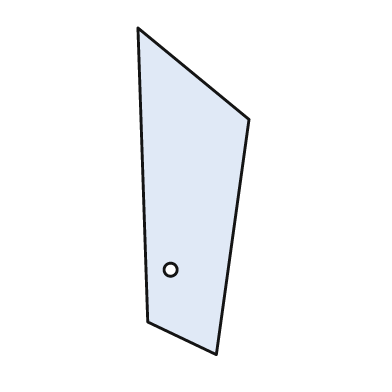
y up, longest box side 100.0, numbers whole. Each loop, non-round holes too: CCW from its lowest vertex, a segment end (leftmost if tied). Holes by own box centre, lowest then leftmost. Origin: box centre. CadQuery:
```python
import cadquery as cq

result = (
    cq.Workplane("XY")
    .moveTo(7.0, -50.0)
    .lineTo(17.0, 22.0)
    .lineTo(-17.0, 50.0)
    .lineTo(-14.0, -40.0)
    .close()
    .moveTo(-7.0, -24.0)
    .circle(2.0)
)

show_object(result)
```